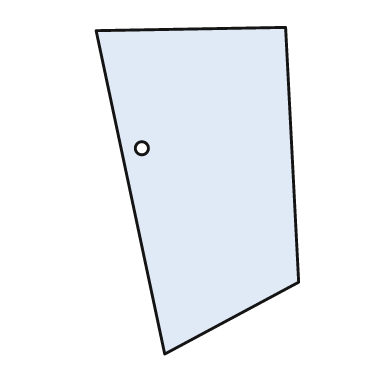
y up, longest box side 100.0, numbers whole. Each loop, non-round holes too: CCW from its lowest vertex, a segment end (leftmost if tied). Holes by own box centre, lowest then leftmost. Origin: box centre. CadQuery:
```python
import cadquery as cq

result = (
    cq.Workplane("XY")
    .moveTo(-10.0, -50.0)
    .lineTo(31.0, -28.0)
    .lineTo(27.0, 50.0)
    .lineTo(-31.0, 49.0)
    .close()
    .moveTo(-17.0, 13.0)
    .circle(2.0)
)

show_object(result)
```